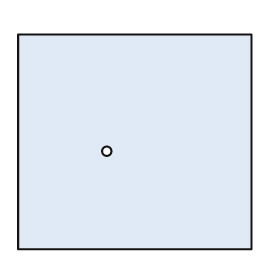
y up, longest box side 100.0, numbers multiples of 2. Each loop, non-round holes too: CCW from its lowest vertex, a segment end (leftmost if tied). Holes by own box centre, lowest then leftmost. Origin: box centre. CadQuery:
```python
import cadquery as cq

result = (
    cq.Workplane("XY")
    .moveTo(-50.0, -46.0)
    .lineTo(50.0, -46.0)
    .lineTo(50.0, 46.0)
    .lineTo(-50.0, 46.0)
    .close()
    .moveTo(-12.0, -4.0)
    .circle(2.0)
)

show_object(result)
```